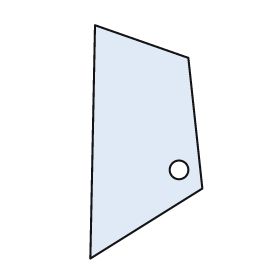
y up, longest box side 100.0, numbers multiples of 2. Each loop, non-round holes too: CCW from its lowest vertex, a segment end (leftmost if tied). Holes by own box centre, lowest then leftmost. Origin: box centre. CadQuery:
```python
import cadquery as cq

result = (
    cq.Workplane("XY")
    .moveTo(-24.0, -50.0)
    .lineTo(24.0, -20.0)
    .lineTo(18.0, 36.0)
    .lineTo(-22.0, 50.0)
    .close()
    .moveTo(14.0, -12.0)
    .circle(4.0)
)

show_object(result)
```